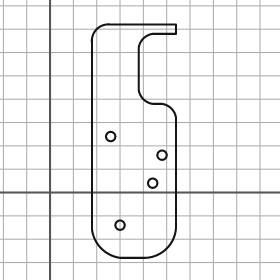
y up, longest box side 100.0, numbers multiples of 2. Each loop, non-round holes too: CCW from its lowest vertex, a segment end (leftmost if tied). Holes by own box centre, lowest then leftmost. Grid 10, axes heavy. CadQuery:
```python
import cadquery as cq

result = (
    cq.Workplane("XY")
    .moveTo(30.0, -28.0)
    .lineTo(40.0, -28.0)
    .threePointArc((50.0, -24.0), (54.0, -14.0))
    .lineTo(54.0, 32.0)
    .threePointArc((52.0, 36.0), (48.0, 38.0))
    .lineTo(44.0, 38.0)
    .threePointArc((40.0, 40.0), (38.0, 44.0))
    .lineTo(38.0, 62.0)
    .threePointArc((40.0, 66.0), (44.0, 68.0))
    .lineTo(54.0, 68.0)
    .lineTo(54.0, 72.0)
    .lineTo(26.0, 72.0)
    .threePointArc((20.0, 70.0), (18.0, 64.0))
    .lineTo(18.0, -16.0)
    .threePointArc((22.0, -24.0), (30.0, -28.0))
    .close()
    .moveTo(30.0, -14.0)
    .circle(2.0)
    .moveTo(44.0, 4.0)
    .circle(2.0)
    .moveTo(48.0, 16.0)
    .circle(2.0)
    .moveTo(26.0, 24.0)
    .circle(2.0)
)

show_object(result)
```